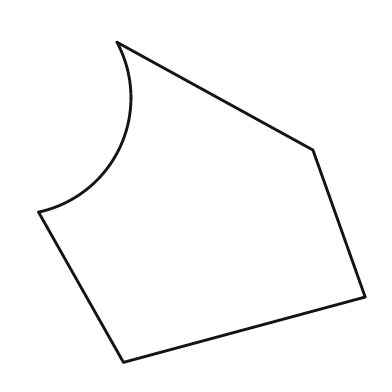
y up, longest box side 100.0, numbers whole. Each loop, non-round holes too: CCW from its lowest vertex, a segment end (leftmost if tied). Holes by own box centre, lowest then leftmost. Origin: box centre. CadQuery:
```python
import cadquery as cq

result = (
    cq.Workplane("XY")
    .moveTo(-24.0, -49.0)
    .lineTo(50.0, -29.0)
    .lineTo(34.0, 16.0)
    .lineTo(-26.0, 49.0)
    .threePointArc((-25.0, 17.0), (-50.0, -3.0))
    .close()
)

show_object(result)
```